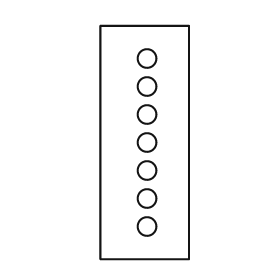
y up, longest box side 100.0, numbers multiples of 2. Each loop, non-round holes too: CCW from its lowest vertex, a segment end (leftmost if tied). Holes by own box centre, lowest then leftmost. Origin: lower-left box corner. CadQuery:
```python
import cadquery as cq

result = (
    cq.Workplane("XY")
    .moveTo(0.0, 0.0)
    .lineTo(38.0, 0.0)
    .lineTo(38.0, 100.0)
    .lineTo(0.0, 100.0)
    .close()
    .moveTo(20.0, 14.0)
    .circle(4.0)
    .moveTo(20.0, 26.0)
    .circle(4.0)
    .moveTo(20.0, 38.0)
    .circle(4.0)
    .moveTo(20.0, 50.0)
    .circle(4.0)
    .moveTo(20.0, 62.0)
    .circle(4.0)
    .moveTo(20.0, 74.0)
    .circle(4.0)
    .moveTo(20.0, 86.0)
    .circle(4.0)
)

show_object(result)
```